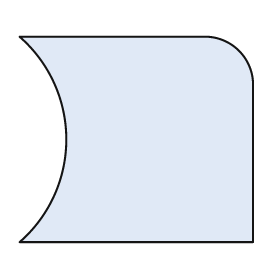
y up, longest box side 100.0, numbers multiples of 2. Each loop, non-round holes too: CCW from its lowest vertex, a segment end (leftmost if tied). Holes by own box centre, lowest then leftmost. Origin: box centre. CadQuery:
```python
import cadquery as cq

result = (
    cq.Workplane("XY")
    .moveTo(-50.0, -44.0)
    .lineTo(50.0, -44.0)
    .lineTo(50.0, 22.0)
    .threePointArc((44.0, 38.0), (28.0, 44.0))
    .lineTo(-50.0, 44.0)
    .threePointArc((-30.0, 0.0), (-50.0, -44.0))
    .close()
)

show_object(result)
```